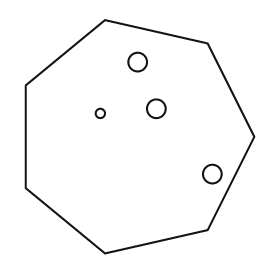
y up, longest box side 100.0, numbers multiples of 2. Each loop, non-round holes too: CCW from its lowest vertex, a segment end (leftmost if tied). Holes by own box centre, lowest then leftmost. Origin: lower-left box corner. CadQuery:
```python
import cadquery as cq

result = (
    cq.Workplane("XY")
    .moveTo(34.0, 0.0)
    .lineTo(78.0, 10.0)
    .lineTo(98.0, 50.0)
    .lineTo(78.0, 90.0)
    .lineTo(34.0, 100.0)
    .lineTo(0.0, 72.0)
    .lineTo(0.0, 28.0)
    .close()
    .moveTo(80.0, 34.0)
    .circle(4.0)
    .moveTo(32.0, 60.0)
    .circle(2.0)
    .moveTo(56.0, 62.0)
    .circle(4.0)
    .moveTo(48.0, 82.0)
    .circle(4.0)
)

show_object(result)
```